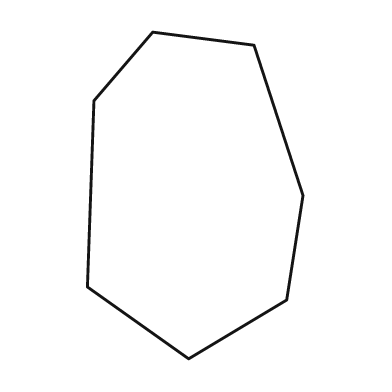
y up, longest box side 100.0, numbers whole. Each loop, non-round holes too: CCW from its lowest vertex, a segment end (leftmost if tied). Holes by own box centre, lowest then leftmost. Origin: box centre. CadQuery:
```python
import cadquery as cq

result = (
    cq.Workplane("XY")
    .moveTo(-2.0, -50.0)
    .lineTo(28.0, -32.0)
    .lineTo(33.0, 0.0)
    .lineTo(18.0, 46.0)
    .lineTo(-13.0, 50.0)
    .lineTo(-31.0, 29.0)
    .lineTo(-33.0, -28.0)
    .close()
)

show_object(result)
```